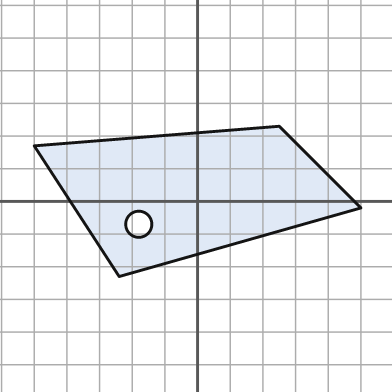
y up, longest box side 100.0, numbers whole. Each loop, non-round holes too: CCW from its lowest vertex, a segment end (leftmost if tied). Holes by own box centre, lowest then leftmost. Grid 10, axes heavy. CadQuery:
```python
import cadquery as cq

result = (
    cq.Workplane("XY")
    .moveTo(-24.0, -23.0)
    .lineTo(50.0, -2.0)
    .lineTo(25.0, 23.0)
    .lineTo(-50.0, 17.0)
    .close()
    .moveTo(-18.0, -7.0)
    .circle(4.0)
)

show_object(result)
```